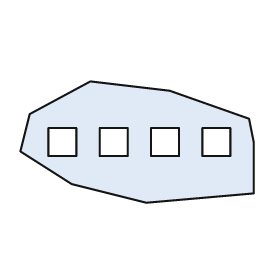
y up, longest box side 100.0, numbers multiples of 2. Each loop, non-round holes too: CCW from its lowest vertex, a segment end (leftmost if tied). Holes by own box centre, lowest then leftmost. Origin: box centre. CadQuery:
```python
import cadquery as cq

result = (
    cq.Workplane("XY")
    .moveTo(4.0, -26.0)
    .lineTo(50.0, -22.0)
    .lineTo(50.0, 0.0)
    .lineTo(48.0, 10.0)
    .lineTo(14.0, 22.0)
    .lineTo(-20.0, 26.0)
    .lineTo(-46.0, 12.0)
    .lineTo(-50.0, -4.0)
    .lineTo(-28.0, -18.0)
    .close()
    .moveTo(-38.0, -6.0)
    .lineTo(-26.0, -6.0)
    .lineTo(-26.0, 6.0)
    .lineTo(-38.0, 6.0)
    .close()
    .moveTo(-16.0, -6.0)
    .lineTo(-4.0, -6.0)
    .lineTo(-4.0, 6.0)
    .lineTo(-16.0, 6.0)
    .close()
    .moveTo(6.0, -6.0)
    .lineTo(18.0, -6.0)
    .lineTo(18.0, 6.0)
    .lineTo(6.0, 6.0)
    .close()
    .moveTo(28.0, -6.0)
    .lineTo(40.0, -6.0)
    .lineTo(40.0, 6.0)
    .lineTo(28.0, 6.0)
    .close()
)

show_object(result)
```